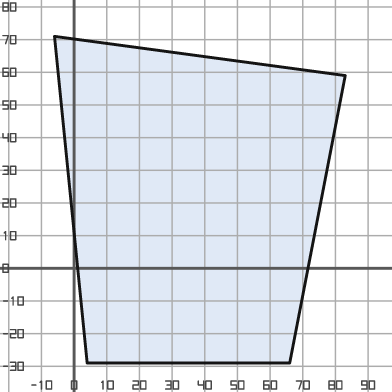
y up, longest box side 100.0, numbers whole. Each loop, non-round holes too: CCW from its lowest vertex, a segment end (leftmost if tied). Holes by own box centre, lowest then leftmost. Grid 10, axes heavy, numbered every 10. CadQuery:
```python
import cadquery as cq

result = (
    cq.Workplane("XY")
    .moveTo(4.0, -29.0)
    .lineTo(66.0, -29.0)
    .lineTo(83.0, 59.0)
    .lineTo(-6.0, 71.0)
    .close()
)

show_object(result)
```